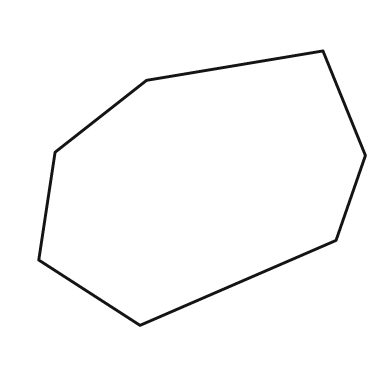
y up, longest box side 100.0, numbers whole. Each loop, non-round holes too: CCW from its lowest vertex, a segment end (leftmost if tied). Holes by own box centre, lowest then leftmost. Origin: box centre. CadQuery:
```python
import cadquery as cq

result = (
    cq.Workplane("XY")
    .moveTo(-19.0, -42.0)
    .lineTo(41.0, -16.0)
    .lineTo(50.0, 10.0)
    .lineTo(37.0, 42.0)
    .lineTo(-17.0, 33.0)
    .lineTo(-45.0, 11.0)
    .lineTo(-50.0, -22.0)
    .close()
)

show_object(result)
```